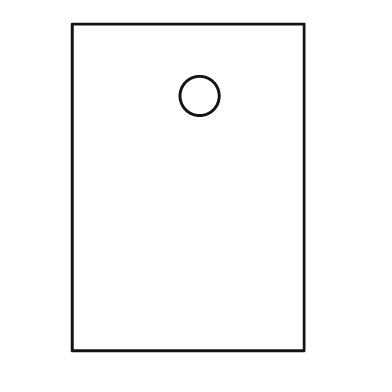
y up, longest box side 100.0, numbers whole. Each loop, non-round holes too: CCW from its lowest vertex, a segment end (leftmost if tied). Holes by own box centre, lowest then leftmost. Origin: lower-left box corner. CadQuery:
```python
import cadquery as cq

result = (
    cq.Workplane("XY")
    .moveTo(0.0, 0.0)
    .lineTo(71.0, 0.0)
    .lineTo(71.0, 100.0)
    .lineTo(0.0, 100.0)
    .close()
    .moveTo(39.0, 78.0)
    .circle(6.0)
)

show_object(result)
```